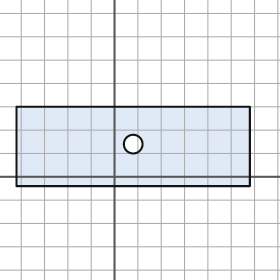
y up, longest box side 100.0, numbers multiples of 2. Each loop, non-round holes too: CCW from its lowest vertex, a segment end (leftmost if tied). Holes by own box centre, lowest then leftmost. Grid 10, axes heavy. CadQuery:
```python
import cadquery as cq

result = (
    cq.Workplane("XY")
    .moveTo(-42.0, -4.0)
    .lineTo(58.0, -4.0)
    .lineTo(58.0, 30.0)
    .lineTo(-42.0, 30.0)
    .close()
    .moveTo(8.0, 14.0)
    .circle(4.0)
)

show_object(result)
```